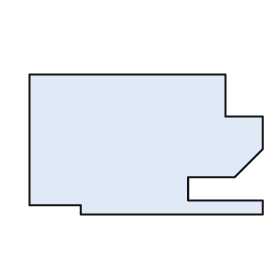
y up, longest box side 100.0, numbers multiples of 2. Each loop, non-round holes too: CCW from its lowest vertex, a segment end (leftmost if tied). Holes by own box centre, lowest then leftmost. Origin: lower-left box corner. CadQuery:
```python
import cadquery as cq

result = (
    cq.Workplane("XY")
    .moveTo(22.0, 0.0)
    .lineTo(100.0, 0.0)
    .lineTo(100.0, 6.0)
    .lineTo(68.0, 6.0)
    .lineTo(68.0, 16.0)
    .lineTo(88.0, 16.0)
    .lineTo(100.0, 28.0)
    .lineTo(100.0, 42.0)
    .lineTo(84.0, 42.0)
    .lineTo(84.0, 60.0)
    .lineTo(0.0, 60.0)
    .lineTo(0.0, 4.0)
    .lineTo(22.0, 4.0)
    .close()
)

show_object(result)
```